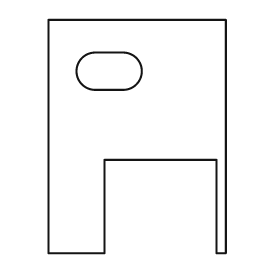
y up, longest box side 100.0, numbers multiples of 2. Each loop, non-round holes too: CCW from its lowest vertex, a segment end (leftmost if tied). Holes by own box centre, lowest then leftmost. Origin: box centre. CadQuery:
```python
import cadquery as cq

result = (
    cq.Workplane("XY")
    .moveTo(-38.0, -50.0)
    .lineTo(-14.0, -50.0)
    .lineTo(-14.0, -10.0)
    .lineTo(34.0, -10.0)
    .lineTo(34.0, -50.0)
    .lineTo(38.0, -50.0)
    .lineTo(38.0, 50.0)
    .lineTo(-38.0, 50.0)
    .close()
    .moveTo(-18.0, 20.0)
    .lineTo(-6.0, 20.0)
    .threePointArc((2.0, 28.0), (-6.0, 36.0))
    .lineTo(-18.0, 36.0)
    .threePointArc((-26.0, 28.0), (-18.0, 20.0))
    .close()
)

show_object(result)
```